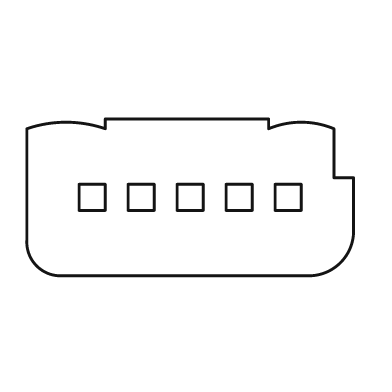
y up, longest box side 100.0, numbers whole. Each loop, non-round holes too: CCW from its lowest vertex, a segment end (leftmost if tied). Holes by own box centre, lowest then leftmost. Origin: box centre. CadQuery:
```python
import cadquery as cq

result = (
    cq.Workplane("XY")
    .moveTo(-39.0, -24.0)
    .lineTo(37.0, -24.0)
    .threePointArc((46.0, -20.0), (50.0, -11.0))
    .lineTo(50.0, 6.0)
    .lineTo(44.0, 6.0)
    .lineTo(44.0, 21.0)
    .threePointArc((34.0, 23.0), (24.0, 21.0))
    .lineTo(24.0, 24.0)
    .lineTo(-26.0, 24.0)
    .lineTo(-26.0, 21.0)
    .threePointArc((-38.0, 23.0), (-50.0, 21.0))
    .lineTo(-50.0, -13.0)
    .threePointArc((-47.0, -21.0), (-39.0, -24.0))
    .close()
    .moveTo(-34.0, -4.0)
    .lineTo(-26.0, -4.0)
    .lineTo(-26.0, 4.0)
    .lineTo(-34.0, 4.0)
    .close()
    .moveTo(-19.0, -4.0)
    .lineTo(-11.0, -4.0)
    .lineTo(-11.0, 4.0)
    .lineTo(-19.0, 4.0)
    .close()
    .moveTo(-4.0, -4.0)
    .lineTo(4.0, -4.0)
    .lineTo(4.0, 4.0)
    .lineTo(-4.0, 4.0)
    .close()
    .moveTo(11.0, -4.0)
    .lineTo(19.0, -4.0)
    .lineTo(19.0, 4.0)
    .lineTo(11.0, 4.0)
    .close()
    .moveTo(26.0, -4.0)
    .lineTo(34.0, -4.0)
    .lineTo(34.0, 4.0)
    .lineTo(26.0, 4.0)
    .close()
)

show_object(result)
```